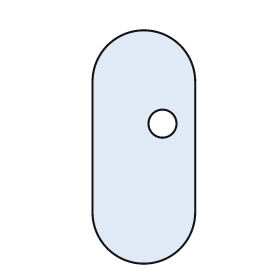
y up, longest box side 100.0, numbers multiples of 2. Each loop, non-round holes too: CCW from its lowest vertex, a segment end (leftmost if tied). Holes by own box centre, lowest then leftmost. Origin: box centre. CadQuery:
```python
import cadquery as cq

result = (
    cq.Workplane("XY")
    .moveTo(-22.0, -28.0)
    .threePointArc((0.0, -50.0), (22.0, -28.0))
    .lineTo(22.0, 28.0)
    .threePointArc((0.0, 50.0), (-22.0, 28.0))
    .close()
    .moveTo(8.0, 10.0)
    .circle(6.0)
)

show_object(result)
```